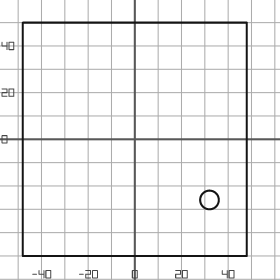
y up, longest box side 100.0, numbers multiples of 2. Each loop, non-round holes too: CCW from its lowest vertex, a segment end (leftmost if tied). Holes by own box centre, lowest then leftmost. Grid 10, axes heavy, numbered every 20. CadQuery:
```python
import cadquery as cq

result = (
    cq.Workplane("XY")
    .moveTo(-48.0, -50.0)
    .lineTo(48.0, -50.0)
    .lineTo(48.0, 50.0)
    .lineTo(-48.0, 50.0)
    .close()
    .moveTo(32.0, -26.0)
    .circle(4.0)
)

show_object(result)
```